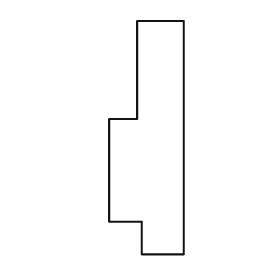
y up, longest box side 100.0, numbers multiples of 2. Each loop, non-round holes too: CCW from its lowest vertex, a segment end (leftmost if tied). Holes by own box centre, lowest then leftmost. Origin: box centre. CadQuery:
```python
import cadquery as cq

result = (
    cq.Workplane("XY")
    .moveTo(-2.0, -50.0)
    .lineTo(16.0, -50.0)
    .lineTo(16.0, 50.0)
    .lineTo(-4.0, 50.0)
    .lineTo(-4.0, 8.0)
    .lineTo(-16.0, 8.0)
    .lineTo(-16.0, -36.0)
    .lineTo(-2.0, -36.0)
    .close()
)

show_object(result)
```